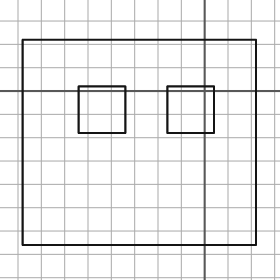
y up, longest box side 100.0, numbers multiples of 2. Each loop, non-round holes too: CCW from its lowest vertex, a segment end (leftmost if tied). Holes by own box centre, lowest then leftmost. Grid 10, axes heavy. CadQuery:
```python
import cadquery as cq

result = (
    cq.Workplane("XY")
    .moveTo(-78.0, -66.0)
    .lineTo(22.0, -66.0)
    .lineTo(22.0, 22.0)
    .lineTo(-78.0, 22.0)
    .close()
    .moveTo(-54.0, -18.0)
    .lineTo(-34.0, -18.0)
    .lineTo(-34.0, 2.0)
    .lineTo(-54.0, 2.0)
    .close()
    .moveTo(-16.0, -18.0)
    .lineTo(4.0, -18.0)
    .lineTo(4.0, 2.0)
    .lineTo(-16.0, 2.0)
    .close()
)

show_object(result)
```